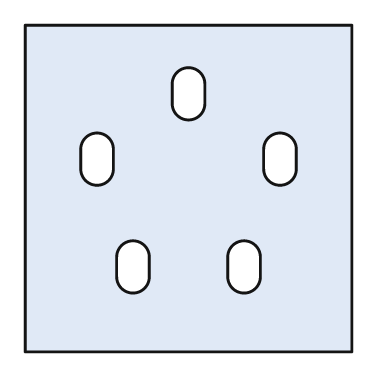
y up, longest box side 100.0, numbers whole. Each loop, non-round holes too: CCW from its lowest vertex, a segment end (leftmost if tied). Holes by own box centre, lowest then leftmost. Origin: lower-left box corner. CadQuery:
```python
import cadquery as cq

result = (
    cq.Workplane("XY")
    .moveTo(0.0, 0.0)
    .lineTo(100.0, 0.0)
    .lineTo(100.0, 100.0)
    .lineTo(0.0, 100.0)
    .close()
    .moveTo(28.0, 23.0)
    .threePointArc((33.0, 18.0), (38.0, 23.0))
    .lineTo(38.0, 29.0)
    .threePointArc((33.0, 34.0), (28.0, 29.0))
    .close()
    .moveTo(62.0, 23.0)
    .threePointArc((67.0, 18.0), (72.0, 23.0))
    .lineTo(72.0, 29.0)
    .threePointArc((67.0, 34.0), (62.0, 29.0))
    .close()
    .moveTo(17.0, 56.0)
    .threePointArc((22.0, 51.0), (27.0, 56.0))
    .lineTo(27.0, 62.0)
    .threePointArc((22.0, 67.0), (17.0, 62.0))
    .close()
    .moveTo(73.0, 56.0)
    .threePointArc((78.0, 51.0), (83.0, 56.0))
    .lineTo(83.0, 62.0)
    .threePointArc((78.0, 67.0), (73.0, 62.0))
    .close()
    .moveTo(45.0, 76.0)
    .threePointArc((50.0, 71.0), (55.0, 76.0))
    .lineTo(55.0, 82.0)
    .threePointArc((50.0, 87.0), (45.0, 82.0))
    .close()
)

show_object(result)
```